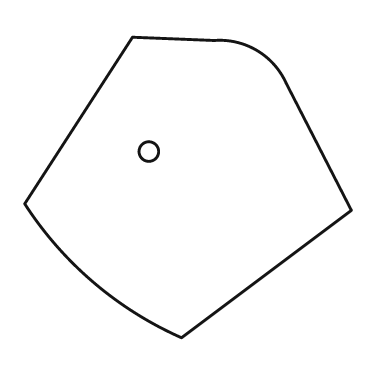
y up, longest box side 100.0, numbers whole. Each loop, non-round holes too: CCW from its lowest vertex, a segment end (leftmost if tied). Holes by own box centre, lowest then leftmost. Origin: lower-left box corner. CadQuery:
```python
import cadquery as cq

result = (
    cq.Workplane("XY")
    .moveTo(48.0, 0.0)
    .lineTo(100.0, 39.0)
    .lineTo(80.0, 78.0)
    .threePointArc((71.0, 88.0), (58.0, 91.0))
    .lineTo(33.0, 92.0)
    .lineTo(0.0, 41.0)
    .threePointArc((21.0, 17.0), (48.0, 0.0))
    .close()
    .moveTo(38.0, 57.0)
    .circle(3.0)
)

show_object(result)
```